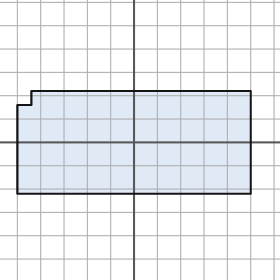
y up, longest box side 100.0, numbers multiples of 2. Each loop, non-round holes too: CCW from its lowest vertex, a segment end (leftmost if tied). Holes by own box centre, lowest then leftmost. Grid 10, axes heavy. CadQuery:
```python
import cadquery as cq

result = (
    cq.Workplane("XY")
    .moveTo(-50.0, -22.0)
    .lineTo(50.0, -22.0)
    .lineTo(50.0, 22.0)
    .lineTo(-44.0, 22.0)
    .lineTo(-44.0, 16.0)
    .lineTo(-50.0, 16.0)
    .close()
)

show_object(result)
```